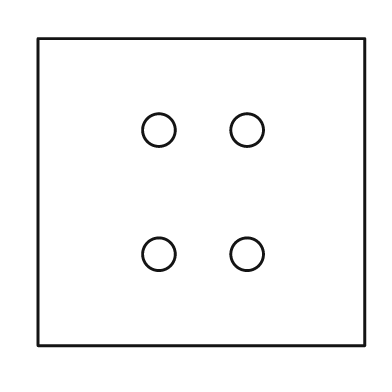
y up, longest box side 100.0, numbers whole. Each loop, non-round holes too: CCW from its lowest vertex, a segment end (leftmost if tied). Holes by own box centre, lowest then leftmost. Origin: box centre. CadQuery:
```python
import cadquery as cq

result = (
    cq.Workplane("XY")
    .moveTo(-50.0, -47.0)
    .lineTo(50.0, -47.0)
    .lineTo(50.0, 47.0)
    .lineTo(-50.0, 47.0)
    .close()
    .moveTo(-13.0, -19.0)
    .circle(5.0)
    .moveTo(14.0, -19.0)
    .circle(5.0)
    .moveTo(-13.0, 19.0)
    .circle(5.0)
    .moveTo(14.0, 19.0)
    .circle(5.0)
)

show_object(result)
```